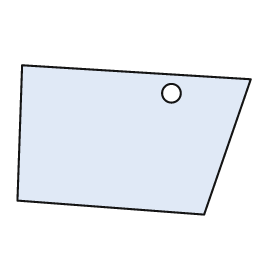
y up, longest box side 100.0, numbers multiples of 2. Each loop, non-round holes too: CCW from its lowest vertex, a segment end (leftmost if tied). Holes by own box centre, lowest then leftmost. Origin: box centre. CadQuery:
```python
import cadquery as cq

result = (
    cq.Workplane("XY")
    .moveTo(30.0, -32.0)
    .lineTo(50.0, 26.0)
    .lineTo(-48.0, 32.0)
    .lineTo(-50.0, -26.0)
    .close()
    .moveTo(16.0, 20.0)
    .circle(4.0)
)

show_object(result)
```